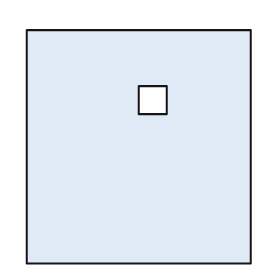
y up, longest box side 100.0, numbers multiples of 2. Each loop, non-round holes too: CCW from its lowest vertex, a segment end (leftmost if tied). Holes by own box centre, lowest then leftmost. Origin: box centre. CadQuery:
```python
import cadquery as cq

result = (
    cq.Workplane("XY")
    .moveTo(-48.0, -50.0)
    .lineTo(48.0, -50.0)
    .lineTo(48.0, 50.0)
    .lineTo(-48.0, 50.0)
    .close()
    .moveTo(0.0, 14.0)
    .lineTo(12.0, 14.0)
    .lineTo(12.0, 26.0)
    .lineTo(0.0, 26.0)
    .close()
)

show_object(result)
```